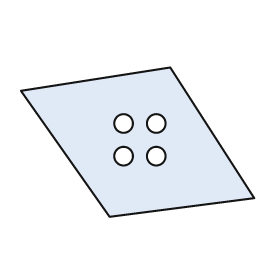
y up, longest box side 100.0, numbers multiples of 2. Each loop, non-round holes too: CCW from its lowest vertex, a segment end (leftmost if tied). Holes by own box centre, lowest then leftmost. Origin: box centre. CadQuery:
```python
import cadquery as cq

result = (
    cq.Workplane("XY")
    .moveTo(-12.0, -32.0)
    .lineTo(50.0, -24.0)
    .lineTo(14.0, 32.0)
    .lineTo(-50.0, 22.0)
    .close()
    .moveTo(-6.0, -6.0)
    .circle(4.0)
    .moveTo(8.0, -6.0)
    .circle(4.0)
    .moveTo(-6.0, 8.0)
    .circle(4.0)
    .moveTo(8.0, 8.0)
    .circle(4.0)
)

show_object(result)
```